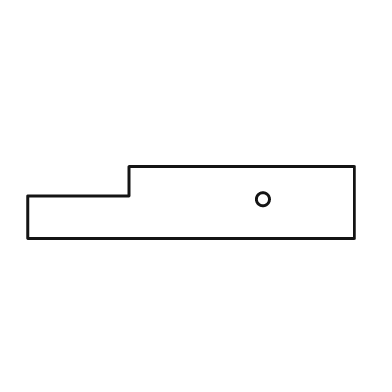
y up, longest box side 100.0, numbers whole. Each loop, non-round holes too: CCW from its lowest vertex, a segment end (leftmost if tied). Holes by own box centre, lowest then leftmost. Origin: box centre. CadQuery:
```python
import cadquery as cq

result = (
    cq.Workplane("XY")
    .moveTo(-50.0, -11.0)
    .lineTo(50.0, -11.0)
    .lineTo(50.0, 11.0)
    .lineTo(-19.0, 11.0)
    .lineTo(-19.0, 2.0)
    .lineTo(-50.0, 2.0)
    .close()
    .moveTo(22.0, 1.0)
    .circle(2.0)
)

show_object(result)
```